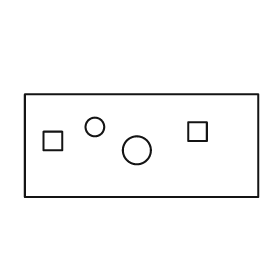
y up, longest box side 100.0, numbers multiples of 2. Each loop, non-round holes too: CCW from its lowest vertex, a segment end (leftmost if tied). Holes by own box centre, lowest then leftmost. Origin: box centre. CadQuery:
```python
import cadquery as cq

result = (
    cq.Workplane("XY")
    .moveTo(-50.0, -22.0)
    .lineTo(50.0, -22.0)
    .lineTo(50.0, 22.0)
    .lineTo(-50.0, 22.0)
    .close()
    .moveTo(-2.0, -2.0)
    .circle(6.0)
    .moveTo(-42.0, -2.0)
    .lineTo(-34.0, -2.0)
    .lineTo(-34.0, 6.0)
    .lineTo(-42.0, 6.0)
    .close()
    .moveTo(20.0, 2.0)
    .lineTo(28.0, 2.0)
    .lineTo(28.0, 10.0)
    .lineTo(20.0, 10.0)
    .close()
    .moveTo(-20.0, 8.0)
    .circle(4.0)
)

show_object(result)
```